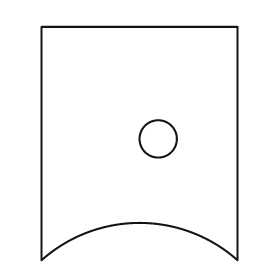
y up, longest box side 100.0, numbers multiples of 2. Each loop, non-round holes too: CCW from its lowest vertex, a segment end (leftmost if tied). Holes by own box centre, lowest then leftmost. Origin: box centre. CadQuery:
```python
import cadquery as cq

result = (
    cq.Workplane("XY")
    .moveTo(-42.0, -50.0)
    .threePointArc((0.0, -34.0), (42.0, -50.0))
    .lineTo(42.0, 50.0)
    .lineTo(-42.0, 50.0)
    .close()
    .moveTo(8.0, 2.0)
    .circle(8.0)
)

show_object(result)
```